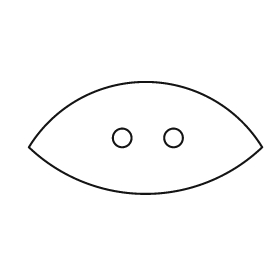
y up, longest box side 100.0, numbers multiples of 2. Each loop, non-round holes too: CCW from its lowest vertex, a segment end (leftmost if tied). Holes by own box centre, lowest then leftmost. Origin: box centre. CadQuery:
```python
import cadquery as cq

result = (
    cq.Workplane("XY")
    .moveTo(-50.0, -4.0)
    .threePointArc((0.0, -24.0), (50.0, -4.0))
    .threePointArc((0.0, 24.0), (-50.0, -4.0))
    .close()
    .moveTo(-10.0, 0.0)
    .circle(4.0)
    .moveTo(12.0, 0.0)
    .circle(4.0)
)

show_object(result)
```